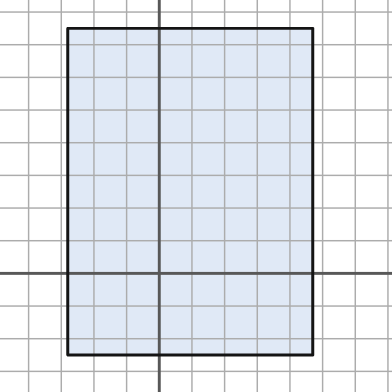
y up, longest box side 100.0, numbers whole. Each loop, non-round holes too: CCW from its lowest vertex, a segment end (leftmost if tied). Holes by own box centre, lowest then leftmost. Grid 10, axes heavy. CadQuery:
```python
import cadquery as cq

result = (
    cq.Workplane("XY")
    .moveTo(-28.0, -25.0)
    .lineTo(47.0, -25.0)
    .lineTo(47.0, 75.0)
    .lineTo(-28.0, 75.0)
    .close()
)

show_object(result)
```